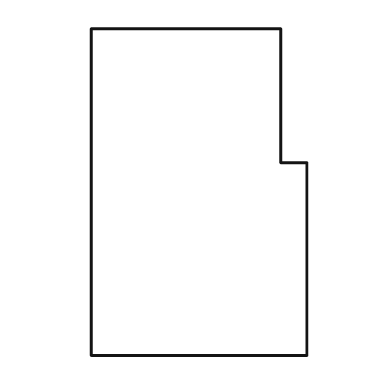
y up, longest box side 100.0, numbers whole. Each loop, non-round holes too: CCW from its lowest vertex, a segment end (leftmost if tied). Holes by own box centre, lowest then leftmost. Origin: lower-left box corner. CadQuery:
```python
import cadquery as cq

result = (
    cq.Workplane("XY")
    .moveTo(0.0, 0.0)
    .lineTo(66.0, 0.0)
    .lineTo(66.0, 59.0)
    .lineTo(58.0, 59.0)
    .lineTo(58.0, 100.0)
    .lineTo(0.0, 100.0)
    .close()
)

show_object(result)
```